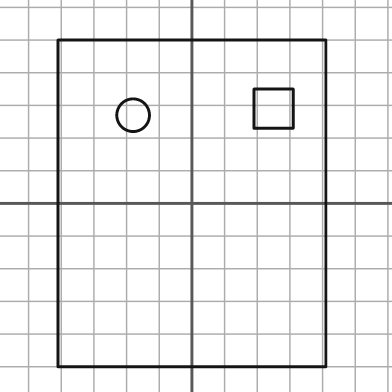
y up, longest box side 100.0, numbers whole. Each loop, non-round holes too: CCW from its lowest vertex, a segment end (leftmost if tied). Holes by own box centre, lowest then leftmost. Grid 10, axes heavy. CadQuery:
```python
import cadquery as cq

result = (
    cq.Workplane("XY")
    .moveTo(-41.0, -50.0)
    .lineTo(41.0, -50.0)
    .lineTo(41.0, 50.0)
    .lineTo(-41.0, 50.0)
    .close()
    .moveTo(-18.0, 27.0)
    .circle(5.0)
    .moveTo(19.0, 23.0)
    .lineTo(31.0, 23.0)
    .lineTo(31.0, 35.0)
    .lineTo(19.0, 35.0)
    .close()
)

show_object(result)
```